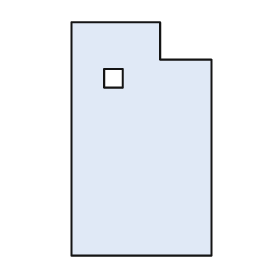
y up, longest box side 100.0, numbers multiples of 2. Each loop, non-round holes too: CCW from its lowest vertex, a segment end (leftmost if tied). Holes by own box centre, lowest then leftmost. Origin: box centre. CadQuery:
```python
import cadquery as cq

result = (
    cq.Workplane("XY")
    .moveTo(-30.0, -50.0)
    .lineTo(30.0, -50.0)
    .lineTo(30.0, 34.0)
    .lineTo(8.0, 34.0)
    .lineTo(8.0, 50.0)
    .lineTo(-30.0, 50.0)
    .close()
    .moveTo(-16.0, 22.0)
    .lineTo(-8.0, 22.0)
    .lineTo(-8.0, 30.0)
    .lineTo(-16.0, 30.0)
    .close()
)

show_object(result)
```